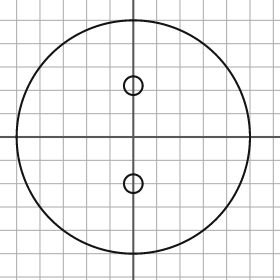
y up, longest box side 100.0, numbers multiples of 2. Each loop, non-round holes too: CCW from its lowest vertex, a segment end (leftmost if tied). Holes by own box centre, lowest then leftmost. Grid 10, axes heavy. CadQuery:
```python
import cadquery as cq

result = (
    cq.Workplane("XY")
    .moveTo(0.0, 0.0)
    .circle(50.0)
    .moveTo(0.0, -20.0)
    .circle(4.0)
    .moveTo(0.0, 22.0)
    .circle(4.0)
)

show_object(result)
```